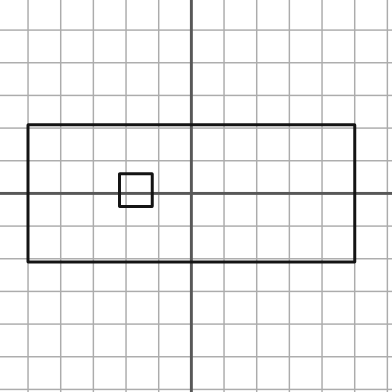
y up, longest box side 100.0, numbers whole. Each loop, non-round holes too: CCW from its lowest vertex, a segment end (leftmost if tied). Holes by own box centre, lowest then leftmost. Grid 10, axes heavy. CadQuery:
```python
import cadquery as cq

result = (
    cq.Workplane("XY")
    .moveTo(-50.0, -21.0)
    .lineTo(50.0, -21.0)
    .lineTo(50.0, 21.0)
    .lineTo(-50.0, 21.0)
    .close()
    .moveTo(-22.0, -4.0)
    .lineTo(-12.0, -4.0)
    .lineTo(-12.0, 6.0)
    .lineTo(-22.0, 6.0)
    .close()
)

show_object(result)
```